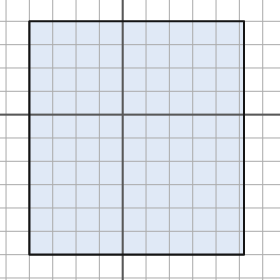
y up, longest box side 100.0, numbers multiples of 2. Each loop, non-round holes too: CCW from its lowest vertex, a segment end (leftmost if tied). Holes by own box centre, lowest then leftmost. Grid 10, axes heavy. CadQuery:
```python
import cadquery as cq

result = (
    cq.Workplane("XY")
    .moveTo(-40.0, -60.0)
    .lineTo(52.0, -60.0)
    .lineTo(52.0, 40.0)
    .lineTo(-40.0, 40.0)
    .close()
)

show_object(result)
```